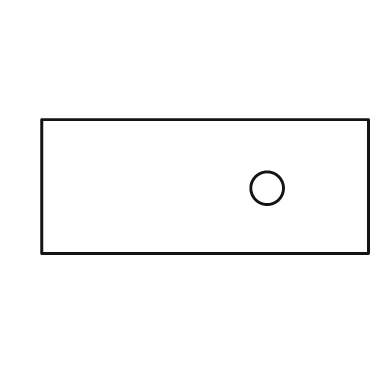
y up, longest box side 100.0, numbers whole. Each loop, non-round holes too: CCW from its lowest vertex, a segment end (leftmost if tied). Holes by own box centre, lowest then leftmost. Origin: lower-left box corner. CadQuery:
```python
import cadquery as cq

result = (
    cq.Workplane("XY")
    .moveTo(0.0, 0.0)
    .lineTo(100.0, 0.0)
    .lineTo(100.0, 41.0)
    .lineTo(0.0, 41.0)
    .close()
    .moveTo(69.0, 20.0)
    .circle(5.0)
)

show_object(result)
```